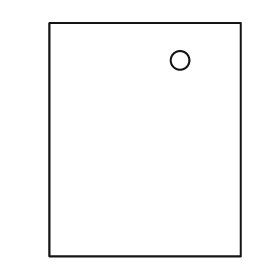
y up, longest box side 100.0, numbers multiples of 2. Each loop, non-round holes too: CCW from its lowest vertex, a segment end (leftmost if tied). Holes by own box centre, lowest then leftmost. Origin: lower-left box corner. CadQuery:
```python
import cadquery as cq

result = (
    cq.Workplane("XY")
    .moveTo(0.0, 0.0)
    .lineTo(82.0, 0.0)
    .lineTo(82.0, 100.0)
    .lineTo(0.0, 100.0)
    .close()
    .moveTo(56.0, 84.0)
    .circle(4.0)
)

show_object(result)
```